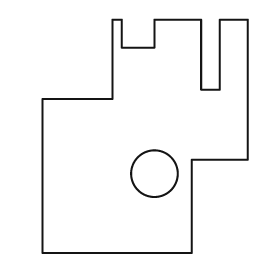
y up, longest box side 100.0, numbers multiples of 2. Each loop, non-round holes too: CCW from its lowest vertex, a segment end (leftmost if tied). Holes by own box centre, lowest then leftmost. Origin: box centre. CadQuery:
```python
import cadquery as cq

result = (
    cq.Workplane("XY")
    .moveTo(-44.0, -50.0)
    .lineTo(20.0, -50.0)
    .lineTo(20.0, -10.0)
    .lineTo(44.0, -10.0)
    .lineTo(44.0, 50.0)
    .lineTo(32.0, 50.0)
    .lineTo(32.0, 20.0)
    .lineTo(24.0, 20.0)
    .lineTo(24.0, 50.0)
    .lineTo(4.0, 50.0)
    .lineTo(4.0, 38.0)
    .lineTo(-10.0, 38.0)
    .lineTo(-10.0, 50.0)
    .lineTo(-14.0, 50.0)
    .lineTo(-14.0, 16.0)
    .lineTo(-44.0, 16.0)
    .close()
    .moveTo(4.0, -16.0)
    .circle(10.0)
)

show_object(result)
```